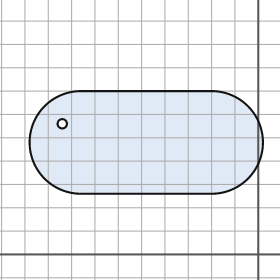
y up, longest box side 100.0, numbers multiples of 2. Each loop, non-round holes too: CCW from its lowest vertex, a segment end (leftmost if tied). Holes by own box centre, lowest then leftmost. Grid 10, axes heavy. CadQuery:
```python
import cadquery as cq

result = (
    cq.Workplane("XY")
    .moveTo(-76.0, 26.0)
    .lineTo(-20.0, 26.0)
    .threePointArc((2.0, 48.0), (-20.0, 70.0))
    .lineTo(-76.0, 70.0)
    .threePointArc((-98.0, 48.0), (-76.0, 26.0))
    .close()
    .moveTo(-84.0, 56.0)
    .circle(2.0)
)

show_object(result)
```